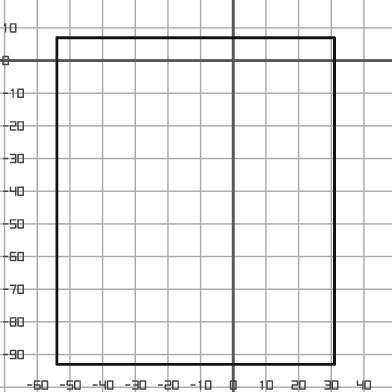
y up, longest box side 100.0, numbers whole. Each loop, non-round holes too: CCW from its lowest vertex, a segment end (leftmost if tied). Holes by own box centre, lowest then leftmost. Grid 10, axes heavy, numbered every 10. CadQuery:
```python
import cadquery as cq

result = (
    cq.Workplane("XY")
    .moveTo(-54.0, -93.0)
    .lineTo(31.0, -93.0)
    .lineTo(31.0, 7.0)
    .lineTo(-54.0, 7.0)
    .close()
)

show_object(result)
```